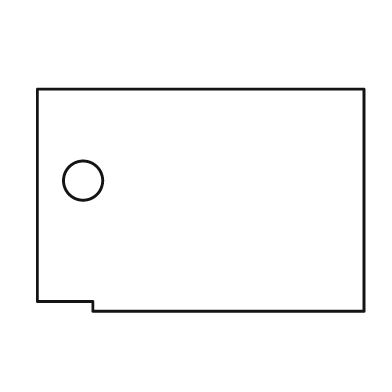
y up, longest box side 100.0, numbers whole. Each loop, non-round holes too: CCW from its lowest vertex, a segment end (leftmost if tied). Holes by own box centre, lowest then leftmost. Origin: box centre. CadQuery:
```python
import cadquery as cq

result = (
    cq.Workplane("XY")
    .moveTo(-33.0, -34.0)
    .lineTo(50.0, -34.0)
    .lineTo(50.0, 34.0)
    .lineTo(-50.0, 34.0)
    .lineTo(-50.0, -31.0)
    .lineTo(-33.0, -31.0)
    .close()
    .moveTo(-36.0, 6.0)
    .circle(6.0)
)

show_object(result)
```